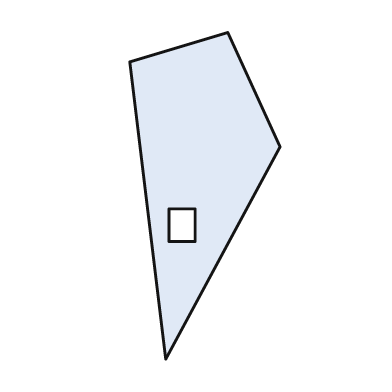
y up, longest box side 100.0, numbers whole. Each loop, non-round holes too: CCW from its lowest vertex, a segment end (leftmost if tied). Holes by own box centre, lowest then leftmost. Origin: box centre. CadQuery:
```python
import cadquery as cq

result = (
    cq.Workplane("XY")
    .moveTo(-12.0, -50.0)
    .lineTo(23.0, 15.0)
    .lineTo(7.0, 50.0)
    .lineTo(-23.0, 41.0)
    .close()
    .moveTo(-11.0, -14.0)
    .lineTo(-3.0, -14.0)
    .lineTo(-3.0, -4.0)
    .lineTo(-11.0, -4.0)
    .close()
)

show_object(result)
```